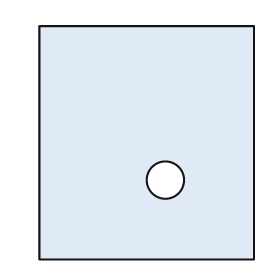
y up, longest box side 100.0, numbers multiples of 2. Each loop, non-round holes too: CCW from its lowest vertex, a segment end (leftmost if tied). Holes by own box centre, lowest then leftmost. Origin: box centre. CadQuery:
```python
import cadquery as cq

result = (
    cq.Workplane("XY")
    .moveTo(-46.0, -50.0)
    .lineTo(46.0, -50.0)
    .lineTo(46.0, 50.0)
    .lineTo(-46.0, 50.0)
    .close()
    .moveTo(8.0, -16.0)
    .circle(8.0)
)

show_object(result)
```